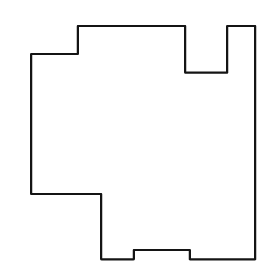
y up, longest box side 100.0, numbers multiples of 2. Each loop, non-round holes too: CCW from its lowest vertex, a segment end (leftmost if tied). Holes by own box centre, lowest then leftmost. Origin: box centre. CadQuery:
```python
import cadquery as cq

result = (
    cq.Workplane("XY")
    .moveTo(-18.0, -50.0)
    .lineTo(-4.0, -50.0)
    .lineTo(-4.0, -46.0)
    .lineTo(20.0, -46.0)
    .lineTo(20.0, -50.0)
    .lineTo(48.0, -50.0)
    .lineTo(48.0, 50.0)
    .lineTo(36.0, 50.0)
    .lineTo(36.0, 30.0)
    .lineTo(18.0, 30.0)
    .lineTo(18.0, 50.0)
    .lineTo(-28.0, 50.0)
    .lineTo(-28.0, 38.0)
    .lineTo(-48.0, 38.0)
    .lineTo(-48.0, -22.0)
    .lineTo(-18.0, -22.0)
    .close()
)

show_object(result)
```